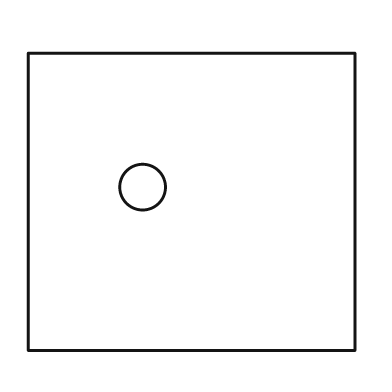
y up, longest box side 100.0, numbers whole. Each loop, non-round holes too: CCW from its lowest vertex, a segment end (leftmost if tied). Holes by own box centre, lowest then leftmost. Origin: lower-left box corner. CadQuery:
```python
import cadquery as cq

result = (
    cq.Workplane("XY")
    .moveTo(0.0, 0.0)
    .lineTo(100.0, 0.0)
    .lineTo(100.0, 91.0)
    .lineTo(0.0, 91.0)
    .close()
    .moveTo(35.0, 50.0)
    .circle(7.0)
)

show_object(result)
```